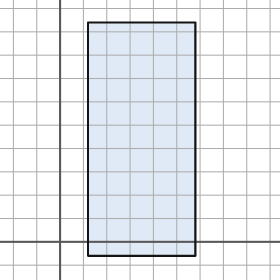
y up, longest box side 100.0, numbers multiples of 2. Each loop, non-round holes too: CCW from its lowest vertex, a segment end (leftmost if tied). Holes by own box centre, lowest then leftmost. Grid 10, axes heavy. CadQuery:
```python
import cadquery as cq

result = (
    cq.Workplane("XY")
    .moveTo(12.0, -6.0)
    .lineTo(58.0, -6.0)
    .lineTo(58.0, 94.0)
    .lineTo(12.0, 94.0)
    .close()
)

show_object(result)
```